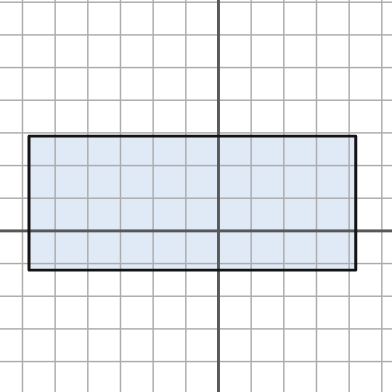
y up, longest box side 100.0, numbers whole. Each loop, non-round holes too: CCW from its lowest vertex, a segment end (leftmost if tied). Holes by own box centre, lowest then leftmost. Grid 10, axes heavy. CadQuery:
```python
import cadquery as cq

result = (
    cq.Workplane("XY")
    .moveTo(-58.0, -12.0)
    .lineTo(42.0, -12.0)
    .lineTo(42.0, 29.0)
    .lineTo(-58.0, 29.0)
    .close()
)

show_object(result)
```